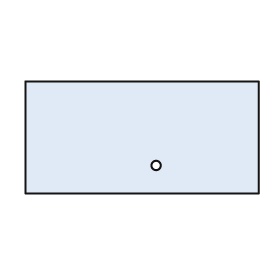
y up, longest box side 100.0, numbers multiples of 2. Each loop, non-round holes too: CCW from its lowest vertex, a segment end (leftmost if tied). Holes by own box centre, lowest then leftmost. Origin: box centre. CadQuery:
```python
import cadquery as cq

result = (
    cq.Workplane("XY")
    .moveTo(-50.0, -24.0)
    .lineTo(50.0, -24.0)
    .lineTo(50.0, 24.0)
    .lineTo(-50.0, 24.0)
    .close()
    .moveTo(6.0, -12.0)
    .circle(2.0)
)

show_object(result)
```